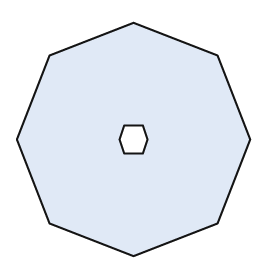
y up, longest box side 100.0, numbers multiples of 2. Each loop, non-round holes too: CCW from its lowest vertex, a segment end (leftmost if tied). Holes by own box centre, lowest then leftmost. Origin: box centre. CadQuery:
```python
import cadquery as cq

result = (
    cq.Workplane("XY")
    .moveTo(0.0, -50.0)
    .lineTo(36.0, -36.0)
    .lineTo(50.0, 0.0)
    .lineTo(36.0, 36.0)
    .lineTo(0.0, 50.0)
    .lineTo(-36.0, 36.0)
    .lineTo(-50.0, 0.0)
    .lineTo(-36.0, -36.0)
    .close()
    .moveTo(-4.0, -6.0)
    .lineTo(4.0, -6.0)
    .lineTo(6.0, 0.0)
    .lineTo(4.0, 6.0)
    .lineTo(-4.0, 6.0)
    .lineTo(-6.0, 0.0)
    .close()
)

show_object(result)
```